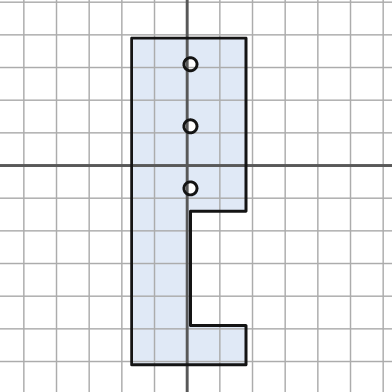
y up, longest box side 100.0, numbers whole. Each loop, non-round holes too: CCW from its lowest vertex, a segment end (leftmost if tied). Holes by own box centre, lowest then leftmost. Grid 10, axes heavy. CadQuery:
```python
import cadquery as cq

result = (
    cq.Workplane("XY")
    .moveTo(-17.0, -61.0)
    .lineTo(18.0, -61.0)
    .lineTo(18.0, -49.0)
    .lineTo(1.0, -49.0)
    .lineTo(1.0, -14.0)
    .lineTo(18.0, -14.0)
    .lineTo(18.0, 39.0)
    .lineTo(-17.0, 39.0)
    .close()
    .moveTo(1.0, -7.0)
    .circle(2.0)
    .moveTo(1.0, 12.0)
    .circle(2.0)
    .moveTo(1.0, 31.0)
    .circle(2.0)
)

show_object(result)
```